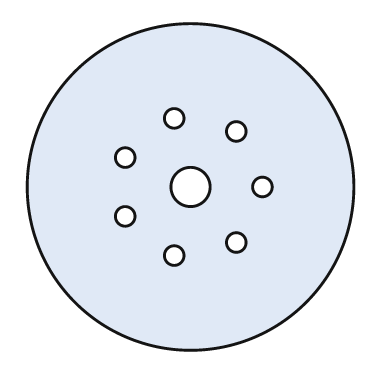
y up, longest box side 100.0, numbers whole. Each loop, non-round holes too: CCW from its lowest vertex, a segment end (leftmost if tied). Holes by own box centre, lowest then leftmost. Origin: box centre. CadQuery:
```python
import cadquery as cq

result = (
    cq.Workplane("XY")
    .moveTo(0.0, 0.0)
    .circle(50.0)
    .moveTo(-5.0, -21.0)
    .circle(3.0)
    .moveTo(14.0, -17.0)
    .circle(3.0)
    .moveTo(-20.0, -9.0)
    .circle(3.0)
    .moveTo(0.0, 0.0)
    .circle(6.0)
    .moveTo(22.0, 0.0)
    .circle(3.0)
    .moveTo(-20.0, 9.0)
    .circle(3.0)
    .moveTo(14.0, 17.0)
    .circle(3.0)
    .moveTo(-5.0, 21.0)
    .circle(3.0)
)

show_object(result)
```